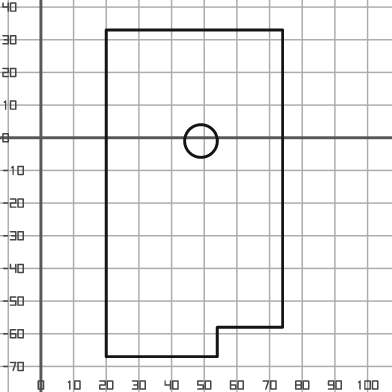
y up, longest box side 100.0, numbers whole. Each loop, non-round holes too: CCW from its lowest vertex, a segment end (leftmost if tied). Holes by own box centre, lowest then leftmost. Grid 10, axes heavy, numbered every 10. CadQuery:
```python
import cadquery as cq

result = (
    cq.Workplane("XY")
    .moveTo(20.0, -67.0)
    .lineTo(54.0, -67.0)
    .lineTo(54.0, -58.0)
    .lineTo(74.0, -58.0)
    .lineTo(74.0, 33.0)
    .lineTo(20.0, 33.0)
    .close()
    .moveTo(49.0, -1.0)
    .circle(5.0)
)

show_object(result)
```